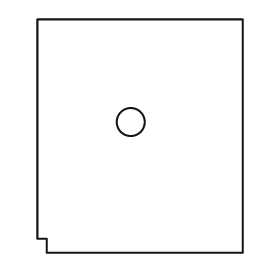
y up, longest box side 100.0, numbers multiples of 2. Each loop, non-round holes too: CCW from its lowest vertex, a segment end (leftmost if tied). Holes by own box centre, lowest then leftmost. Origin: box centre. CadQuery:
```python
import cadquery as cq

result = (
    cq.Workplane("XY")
    .moveTo(-40.0, -50.0)
    .lineTo(44.0, -50.0)
    .lineTo(44.0, 50.0)
    .lineTo(-44.0, 50.0)
    .lineTo(-44.0, -44.0)
    .lineTo(-40.0, -44.0)
    .close()
    .moveTo(-4.0, 6.0)
    .circle(6.0)
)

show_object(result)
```